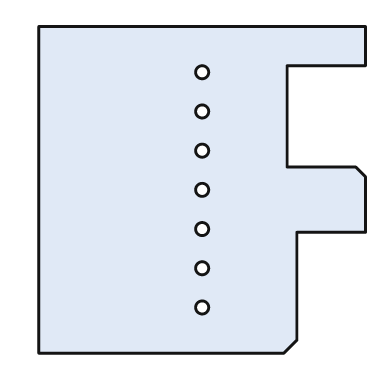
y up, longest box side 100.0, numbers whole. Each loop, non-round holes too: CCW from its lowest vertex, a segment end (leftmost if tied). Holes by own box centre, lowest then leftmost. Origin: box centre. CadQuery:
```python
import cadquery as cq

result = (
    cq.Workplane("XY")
    .moveTo(-50.0, -50.0)
    .lineTo(25.0, -50.0)
    .lineTo(29.0, -46.0)
    .lineTo(29.0, -13.0)
    .lineTo(50.0, -13.0)
    .lineTo(50.0, 4.0)
    .lineTo(47.0, 7.0)
    .lineTo(26.0, 7.0)
    .lineTo(26.0, 38.0)
    .lineTo(50.0, 38.0)
    .lineTo(50.0, 50.0)
    .lineTo(-50.0, 50.0)
    .close()
    .moveTo(0.0, -36.0)
    .circle(2.0)
    .moveTo(0.0, -24.0)
    .circle(2.0)
    .moveTo(0.0, -12.0)
    .circle(2.0)
    .moveTo(0.0, 0.0)
    .circle(2.0)
    .moveTo(0.0, 12.0)
    .circle(2.0)
    .moveTo(0.0, 24.0)
    .circle(2.0)
    .moveTo(0.0, 36.0)
    .circle(2.0)
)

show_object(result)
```